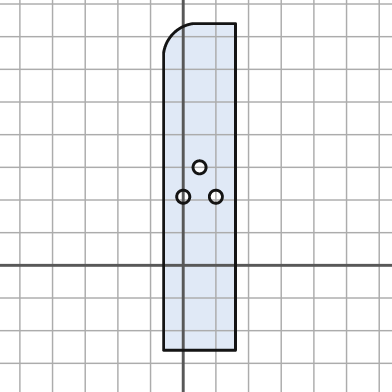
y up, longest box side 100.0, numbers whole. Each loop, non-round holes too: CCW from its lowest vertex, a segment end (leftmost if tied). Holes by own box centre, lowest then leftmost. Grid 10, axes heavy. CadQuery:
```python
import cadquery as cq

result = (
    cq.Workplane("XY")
    .moveTo(-6.0, -26.0)
    .lineTo(16.0, -26.0)
    .lineTo(16.0, 74.0)
    .lineTo(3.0, 74.0)
    .threePointArc((-3.0, 71.0), (-6.0, 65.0))
    .close()
    .moveTo(0.0, 21.0)
    .circle(2.0)
    .moveTo(10.0, 21.0)
    .circle(2.0)
    .moveTo(5.0, 30.0)
    .circle(2.0)
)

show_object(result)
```